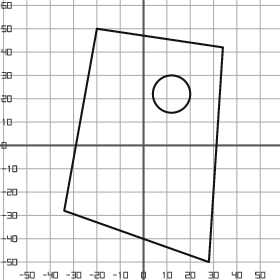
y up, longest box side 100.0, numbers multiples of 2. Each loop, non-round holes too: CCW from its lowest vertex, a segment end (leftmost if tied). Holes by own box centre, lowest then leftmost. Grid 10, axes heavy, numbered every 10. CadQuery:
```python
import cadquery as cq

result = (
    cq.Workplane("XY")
    .moveTo(28.0, -50.0)
    .lineTo(34.0, 42.0)
    .lineTo(-20.0, 50.0)
    .lineTo(-34.0, -28.0)
    .close()
    .moveTo(12.0, 22.0)
    .circle(8.0)
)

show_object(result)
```